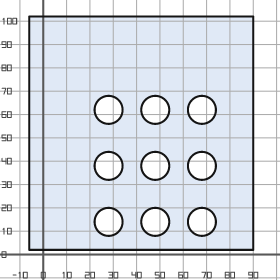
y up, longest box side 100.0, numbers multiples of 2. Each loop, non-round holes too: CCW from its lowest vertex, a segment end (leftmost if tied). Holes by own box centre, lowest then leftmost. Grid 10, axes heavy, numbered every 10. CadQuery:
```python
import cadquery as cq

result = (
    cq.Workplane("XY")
    .moveTo(-6.0, 2.0)
    .lineTo(90.0, 2.0)
    .lineTo(90.0, 102.0)
    .lineTo(-6.0, 102.0)
    .close()
    .moveTo(28.0, 14.0)
    .circle(6.0)
    .moveTo(48.0, 14.0)
    .circle(6.0)
    .moveTo(68.0, 14.0)
    .circle(6.0)
    .moveTo(28.0, 38.0)
    .circle(6.0)
    .moveTo(48.0, 38.0)
    .circle(6.0)
    .moveTo(68.0, 38.0)
    .circle(6.0)
    .moveTo(28.0, 62.0)
    .circle(6.0)
    .moveTo(48.0, 62.0)
    .circle(6.0)
    .moveTo(68.0, 62.0)
    .circle(6.0)
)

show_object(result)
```